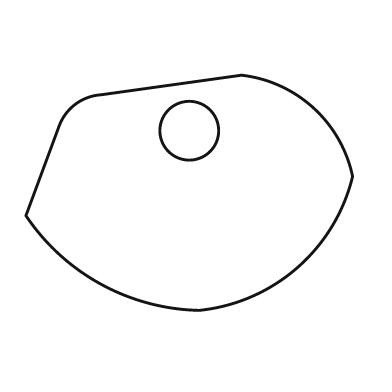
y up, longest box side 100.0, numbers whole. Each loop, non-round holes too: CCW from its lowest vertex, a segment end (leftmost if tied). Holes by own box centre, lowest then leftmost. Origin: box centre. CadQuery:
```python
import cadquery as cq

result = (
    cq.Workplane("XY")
    .moveTo(3.0, -36.0)
    .threePointArc((33.0, -23.0), (50.0, 5.0))
    .threePointArc((38.0, 26.0), (16.0, 36.0))
    .lineTo(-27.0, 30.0)
    .threePointArc((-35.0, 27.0), (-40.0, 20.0))
    .lineTo(-50.0, -7.0)
    .threePointArc((-27.0, -28.0), (3.0, -36.0))
    .close()
    .moveTo(0.0, 19.0)
    .circle(9.0)
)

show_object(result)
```